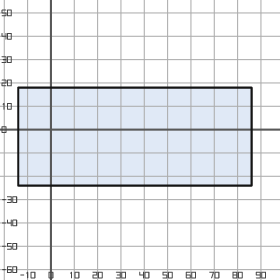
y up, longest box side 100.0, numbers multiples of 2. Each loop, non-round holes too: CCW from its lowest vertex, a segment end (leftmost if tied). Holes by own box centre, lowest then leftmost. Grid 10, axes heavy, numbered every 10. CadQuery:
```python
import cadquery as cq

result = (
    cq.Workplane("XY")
    .moveTo(-14.0, -24.0)
    .lineTo(86.0, -24.0)
    .lineTo(86.0, 18.0)
    .lineTo(-14.0, 18.0)
    .close()
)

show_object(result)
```